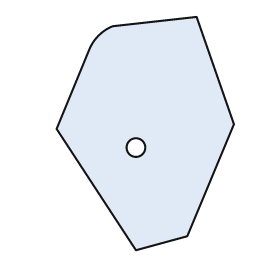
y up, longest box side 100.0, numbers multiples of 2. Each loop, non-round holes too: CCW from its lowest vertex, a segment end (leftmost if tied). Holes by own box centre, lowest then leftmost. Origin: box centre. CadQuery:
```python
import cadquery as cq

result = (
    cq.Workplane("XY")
    .moveTo(-4.0, -50.0)
    .lineTo(18.0, -44.0)
    .lineTo(38.0, 4.0)
    .lineTo(22.0, 50.0)
    .lineTo(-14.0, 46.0)
    .threePointArc((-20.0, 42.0), (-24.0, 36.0))
    .lineTo(-38.0, 2.0)
    .close()
    .moveTo(-4.0, -6.0)
    .circle(4.0)
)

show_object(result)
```